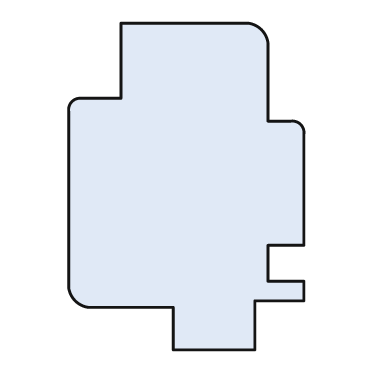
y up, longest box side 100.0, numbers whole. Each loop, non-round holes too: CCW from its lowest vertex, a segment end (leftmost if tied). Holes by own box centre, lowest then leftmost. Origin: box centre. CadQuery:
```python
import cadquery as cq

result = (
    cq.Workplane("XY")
    .moveTo(-4.0, -50.0)
    .lineTo(21.0, -50.0)
    .lineTo(21.0, -35.0)
    .lineTo(36.0, -35.0)
    .lineTo(36.0, -29.0)
    .lineTo(25.0, -29.0)
    .lineTo(25.0, -18.0)
    .lineTo(36.0, -18.0)
    .lineTo(36.0, 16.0)
    .threePointArc((35.0, 19.0), (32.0, 20.0))
    .lineTo(25.0, 20.0)
    .lineTo(25.0, 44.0)
    .threePointArc((23.0, 48.0), (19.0, 50.0))
    .lineTo(-20.0, 50.0)
    .lineTo(-20.0, 27.0)
    .lineTo(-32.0, 27.0)
    .threePointArc((-35.0, 26.0), (-36.0, 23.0))
    .lineTo(-36.0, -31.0)
    .threePointArc((-34.0, -35.0), (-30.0, -37.0))
    .lineTo(-4.0, -37.0)
    .close()
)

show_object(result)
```